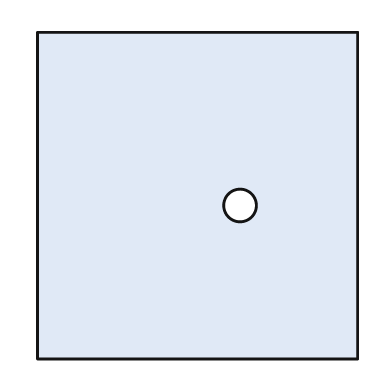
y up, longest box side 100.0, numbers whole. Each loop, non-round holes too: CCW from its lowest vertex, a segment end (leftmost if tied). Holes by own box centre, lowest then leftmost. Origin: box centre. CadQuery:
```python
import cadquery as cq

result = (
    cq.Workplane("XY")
    .moveTo(-49.0, -50.0)
    .lineTo(49.0, -50.0)
    .lineTo(49.0, 50.0)
    .lineTo(-49.0, 50.0)
    .close()
    .moveTo(13.0, -3.0)
    .circle(5.0)
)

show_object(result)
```